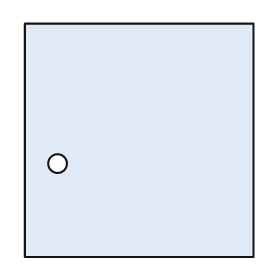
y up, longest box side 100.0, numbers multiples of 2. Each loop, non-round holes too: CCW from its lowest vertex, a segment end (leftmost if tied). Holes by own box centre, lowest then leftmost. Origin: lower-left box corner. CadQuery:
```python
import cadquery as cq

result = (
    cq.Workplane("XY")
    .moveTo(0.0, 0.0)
    .lineTo(98.0, 0.0)
    .lineTo(98.0, 100.0)
    .lineTo(0.0, 100.0)
    .close()
    .moveTo(14.0, 40.0)
    .circle(4.0)
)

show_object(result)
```